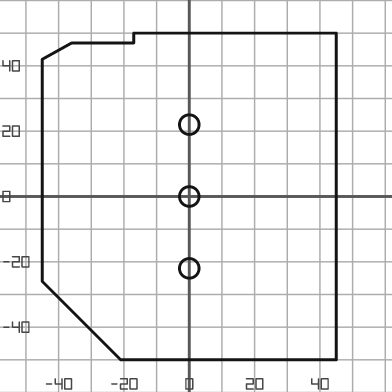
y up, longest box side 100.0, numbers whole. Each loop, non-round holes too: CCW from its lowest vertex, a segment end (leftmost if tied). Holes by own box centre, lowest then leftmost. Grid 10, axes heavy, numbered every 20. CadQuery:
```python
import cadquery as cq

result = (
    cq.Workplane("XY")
    .moveTo(-21.0, -50.0)
    .lineTo(45.0, -50.0)
    .lineTo(45.0, 50.0)
    .lineTo(-17.0, 50.0)
    .lineTo(-17.0, 47.0)
    .lineTo(-36.0, 47.0)
    .lineTo(-45.0, 42.0)
    .lineTo(-45.0, -26.0)
    .close()
    .moveTo(0.0, -22.0)
    .circle(3.0)
    .moveTo(0.0, 0.0)
    .circle(3.0)
    .moveTo(0.0, 22.0)
    .circle(3.0)
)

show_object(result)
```